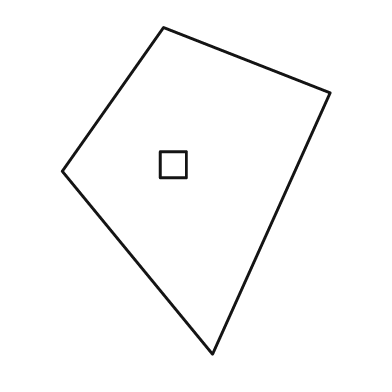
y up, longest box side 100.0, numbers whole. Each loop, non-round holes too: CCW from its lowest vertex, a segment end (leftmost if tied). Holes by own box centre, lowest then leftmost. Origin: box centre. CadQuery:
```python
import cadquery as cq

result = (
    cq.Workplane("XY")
    .moveTo(5.0, -50.0)
    .lineTo(41.0, 30.0)
    .lineTo(-10.0, 50.0)
    .lineTo(-41.0, 6.0)
    .close()
    .moveTo(-11.0, 4.0)
    .lineTo(-3.0, 4.0)
    .lineTo(-3.0, 12.0)
    .lineTo(-11.0, 12.0)
    .close()
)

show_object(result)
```